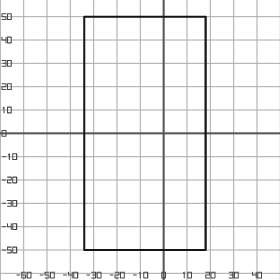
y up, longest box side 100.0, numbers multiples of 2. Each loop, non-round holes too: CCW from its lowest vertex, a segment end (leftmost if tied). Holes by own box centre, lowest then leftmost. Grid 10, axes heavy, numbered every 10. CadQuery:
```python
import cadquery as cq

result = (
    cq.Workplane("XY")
    .moveTo(-34.0, -50.0)
    .lineTo(18.0, -50.0)
    .lineTo(18.0, 50.0)
    .lineTo(-34.0, 50.0)
    .close()
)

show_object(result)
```